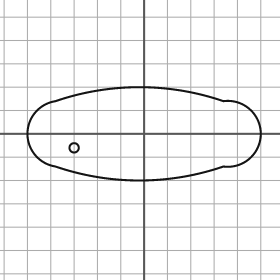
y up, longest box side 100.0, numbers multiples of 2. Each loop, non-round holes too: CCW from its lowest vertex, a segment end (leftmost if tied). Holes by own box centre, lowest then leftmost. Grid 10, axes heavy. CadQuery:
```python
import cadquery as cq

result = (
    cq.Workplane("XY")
    .moveTo(-38.0, -14.0)
    .threePointArc((-2.0, -20.0), (34.0, -14.0))
    .threePointArc((50.0, 0.0), (34.0, 14.0))
    .threePointArc((-2.0, 20.0), (-38.0, 14.0))
    .threePointArc((-50.0, 0.0), (-38.0, -14.0))
    .close()
    .moveTo(-30.0, -6.0)
    .circle(2.0)
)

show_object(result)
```